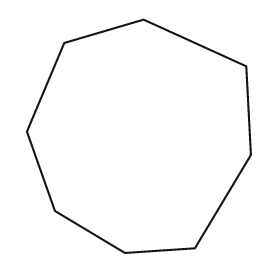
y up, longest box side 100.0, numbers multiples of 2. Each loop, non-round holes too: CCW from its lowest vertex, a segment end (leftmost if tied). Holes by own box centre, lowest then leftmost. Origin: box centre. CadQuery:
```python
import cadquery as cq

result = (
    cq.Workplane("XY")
    .moveTo(-6.0, -50.0)
    .lineTo(24.0, -48.0)
    .lineTo(48.0, -8.0)
    .lineTo(46.0, 30.0)
    .lineTo(2.0, 50.0)
    .lineTo(-32.0, 40.0)
    .lineTo(-48.0, 2.0)
    .lineTo(-36.0, -32.0)
    .close()
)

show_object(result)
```